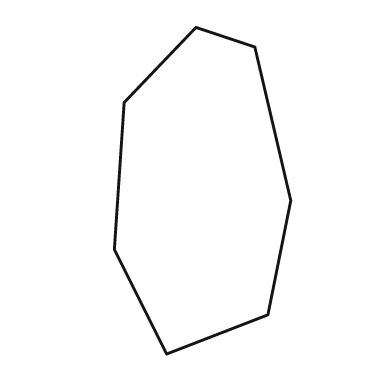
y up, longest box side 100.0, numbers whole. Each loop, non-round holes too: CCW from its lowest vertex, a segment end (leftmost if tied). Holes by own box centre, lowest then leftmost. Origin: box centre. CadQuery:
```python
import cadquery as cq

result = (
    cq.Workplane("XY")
    .moveTo(-11.0, -50.0)
    .lineTo(20.0, -38.0)
    .lineTo(27.0, -3.0)
    .lineTo(16.0, 44.0)
    .lineTo(-2.0, 50.0)
    .lineTo(-24.0, 27.0)
    .lineTo(-27.0, -18.0)
    .close()
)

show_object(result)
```